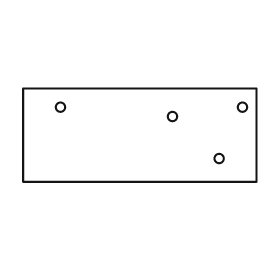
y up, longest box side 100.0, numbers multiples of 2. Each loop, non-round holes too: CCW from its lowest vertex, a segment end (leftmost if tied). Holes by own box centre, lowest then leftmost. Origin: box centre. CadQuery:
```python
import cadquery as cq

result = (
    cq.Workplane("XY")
    .moveTo(-50.0, -20.0)
    .lineTo(50.0, -20.0)
    .lineTo(50.0, 20.0)
    .lineTo(-50.0, 20.0)
    .close()
    .moveTo(34.0, -10.0)
    .circle(2.0)
    .moveTo(14.0, 8.0)
    .circle(2.0)
    .moveTo(-34.0, 12.0)
    .circle(2.0)
    .moveTo(44.0, 12.0)
    .circle(2.0)
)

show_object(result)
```